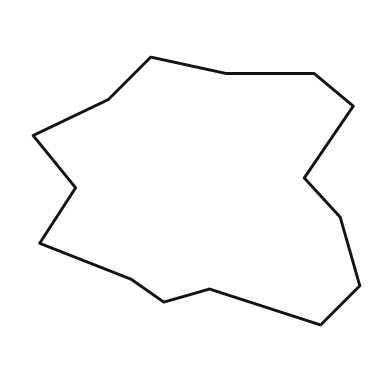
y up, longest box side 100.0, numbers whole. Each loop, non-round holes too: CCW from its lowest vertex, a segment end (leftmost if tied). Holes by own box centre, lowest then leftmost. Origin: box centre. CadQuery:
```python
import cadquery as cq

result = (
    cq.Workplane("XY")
    .moveTo(38.0, -41.0)
    .lineTo(50.0, -29.0)
    .lineTo(44.0, -8.0)
    .lineTo(33.0, 4.0)
    .lineTo(48.0, 26.0)
    .lineTo(36.0, 36.0)
    .lineTo(9.0, 36.0)
    .lineTo(-14.0, 41.0)
    .lineTo(-27.0, 28.0)
    .lineTo(-50.0, 17.0)
    .lineTo(-37.0, 1.0)
    .lineTo(-48.0, -16.0)
    .lineTo(-20.0, -27.0)
    .lineTo(-10.0, -34.0)
    .lineTo(4.0, -30.0)
    .close()
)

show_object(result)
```